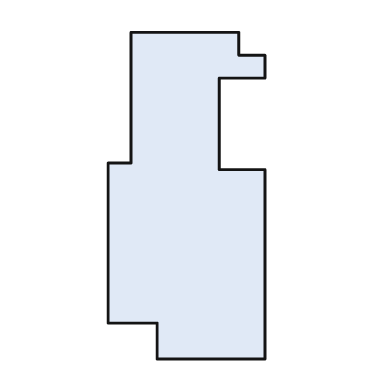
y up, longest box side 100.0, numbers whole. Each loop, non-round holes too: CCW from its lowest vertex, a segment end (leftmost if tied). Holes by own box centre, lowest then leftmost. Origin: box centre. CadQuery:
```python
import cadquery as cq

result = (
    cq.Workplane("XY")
    .moveTo(-9.0, -50.0)
    .lineTo(24.0, -50.0)
    .lineTo(24.0, 8.0)
    .lineTo(10.0, 8.0)
    .lineTo(10.0, 36.0)
    .lineTo(24.0, 36.0)
    .lineTo(24.0, 43.0)
    .lineTo(16.0, 43.0)
    .lineTo(16.0, 50.0)
    .lineTo(-17.0, 50.0)
    .lineTo(-17.0, 10.0)
    .lineTo(-24.0, 10.0)
    .lineTo(-24.0, -39.0)
    .lineTo(-9.0, -39.0)
    .close()
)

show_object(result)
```